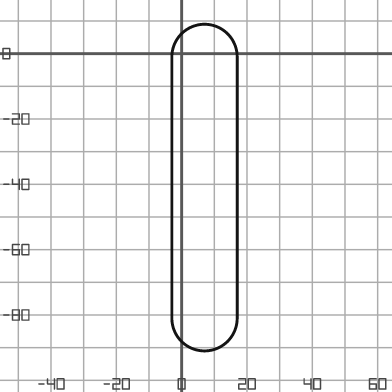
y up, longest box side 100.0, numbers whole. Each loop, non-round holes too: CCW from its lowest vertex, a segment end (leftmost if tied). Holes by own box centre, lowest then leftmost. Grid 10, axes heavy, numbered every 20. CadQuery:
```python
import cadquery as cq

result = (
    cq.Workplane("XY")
    .moveTo(-3.0, -81.0)
    .threePointArc((7.0, -91.0), (17.0, -81.0))
    .lineTo(17.0, -1.0)
    .threePointArc((7.0, 9.0), (-3.0, -1.0))
    .close()
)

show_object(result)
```